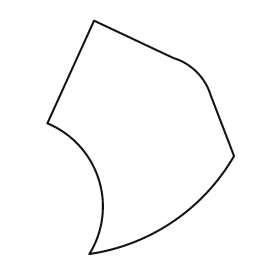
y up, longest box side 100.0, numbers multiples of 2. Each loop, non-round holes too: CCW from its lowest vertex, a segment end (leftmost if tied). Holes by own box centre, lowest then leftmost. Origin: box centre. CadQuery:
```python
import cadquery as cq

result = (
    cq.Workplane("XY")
    .moveTo(-22.0, -50.0)
    .threePointArc((14.0, -36.0), (40.0, -8.0))
    .lineTo(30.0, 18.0)
    .threePointArc((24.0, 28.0), (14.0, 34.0))
    .lineTo(-20.0, 50.0)
    .lineTo(-40.0, 6.0)
    .threePointArc((-18.0, -18.0), (-22.0, -50.0))
    .close()
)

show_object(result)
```